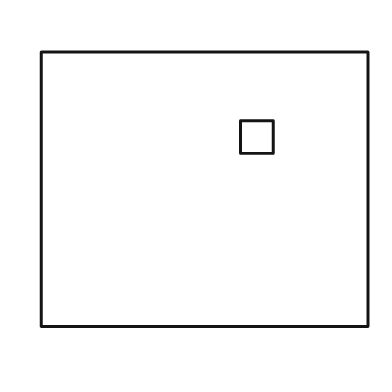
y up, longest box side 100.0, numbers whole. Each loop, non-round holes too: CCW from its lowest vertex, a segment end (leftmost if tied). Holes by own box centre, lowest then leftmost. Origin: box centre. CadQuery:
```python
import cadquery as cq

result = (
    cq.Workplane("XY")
    .moveTo(-50.0, -42.0)
    .lineTo(50.0, -42.0)
    .lineTo(50.0, 42.0)
    .lineTo(-50.0, 42.0)
    .close()
    .moveTo(11.0, 11.0)
    .lineTo(21.0, 11.0)
    .lineTo(21.0, 21.0)
    .lineTo(11.0, 21.0)
    .close()
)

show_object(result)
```